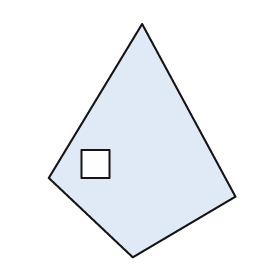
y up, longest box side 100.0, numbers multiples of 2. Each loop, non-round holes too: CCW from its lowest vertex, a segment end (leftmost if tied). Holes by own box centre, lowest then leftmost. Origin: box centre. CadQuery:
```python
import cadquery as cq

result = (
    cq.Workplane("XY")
    .moveTo(-4.0, -50.0)
    .lineTo(40.0, -24.0)
    .lineTo(0.0, 50.0)
    .lineTo(-40.0, -16.0)
    .close()
    .moveTo(-26.0, -16.0)
    .lineTo(-14.0, -16.0)
    .lineTo(-14.0, -4.0)
    .lineTo(-26.0, -4.0)
    .close()
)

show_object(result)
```